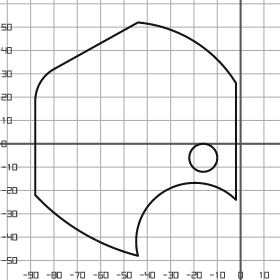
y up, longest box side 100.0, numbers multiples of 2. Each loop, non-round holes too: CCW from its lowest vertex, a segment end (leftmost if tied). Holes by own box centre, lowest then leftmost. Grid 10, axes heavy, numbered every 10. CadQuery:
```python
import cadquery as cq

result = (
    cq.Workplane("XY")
    .moveTo(-44.0, -48.0)
    .threePointArc((-32.0, -20.0), (-2.0, -24.0))
    .lineTo(-2.0, 26.0)
    .threePointArc((-20.0, 44.0), (-44.0, 52.0))
    .lineTo(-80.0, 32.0)
    .threePointArc((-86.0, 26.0), (-88.0, 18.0))
    .lineTo(-88.0, -22.0)
    .threePointArc((-68.0, -38.0), (-44.0, -48.0))
    .close()
    .moveTo(-16.0, -6.0)
    .circle(6.0)
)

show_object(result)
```